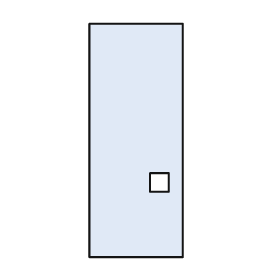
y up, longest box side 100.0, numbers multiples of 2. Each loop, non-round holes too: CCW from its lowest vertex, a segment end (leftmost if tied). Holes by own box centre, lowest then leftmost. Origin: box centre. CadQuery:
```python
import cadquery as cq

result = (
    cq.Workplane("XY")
    .moveTo(-20.0, -50.0)
    .lineTo(20.0, -50.0)
    .lineTo(20.0, 50.0)
    .lineTo(-20.0, 50.0)
    .close()
    .moveTo(6.0, -22.0)
    .lineTo(14.0, -22.0)
    .lineTo(14.0, -14.0)
    .lineTo(6.0, -14.0)
    .close()
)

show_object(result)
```